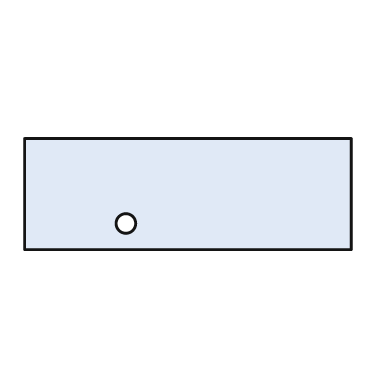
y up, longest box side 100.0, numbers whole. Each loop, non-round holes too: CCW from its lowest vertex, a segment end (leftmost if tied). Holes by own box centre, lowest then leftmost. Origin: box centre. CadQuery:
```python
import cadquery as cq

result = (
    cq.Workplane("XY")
    .moveTo(-50.0, -17.0)
    .lineTo(50.0, -17.0)
    .lineTo(50.0, 17.0)
    .lineTo(-50.0, 17.0)
    .close()
    .moveTo(-19.0, -9.0)
    .circle(3.0)
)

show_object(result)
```